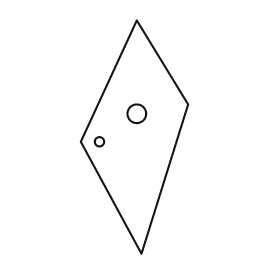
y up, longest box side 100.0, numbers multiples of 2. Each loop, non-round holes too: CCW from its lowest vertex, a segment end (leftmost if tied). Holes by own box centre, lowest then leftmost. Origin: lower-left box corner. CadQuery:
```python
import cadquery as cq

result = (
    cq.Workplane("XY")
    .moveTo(26.0, 0.0)
    .lineTo(46.0, 64.0)
    .lineTo(24.0, 100.0)
    .lineTo(0.0, 48.0)
    .close()
    .moveTo(8.0, 48.0)
    .circle(2.0)
    .moveTo(24.0, 60.0)
    .circle(4.0)
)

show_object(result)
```